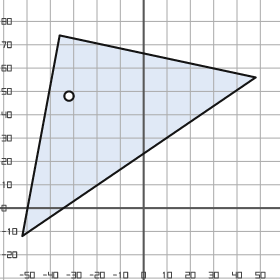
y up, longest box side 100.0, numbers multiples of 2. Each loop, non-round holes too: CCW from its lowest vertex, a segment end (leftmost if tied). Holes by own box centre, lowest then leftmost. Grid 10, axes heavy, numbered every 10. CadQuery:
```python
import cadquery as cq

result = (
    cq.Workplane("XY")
    .moveTo(-52.0, -12.0)
    .lineTo(48.0, 56.0)
    .lineTo(-36.0, 74.0)
    .close()
    .moveTo(-32.0, 48.0)
    .circle(2.0)
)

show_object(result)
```